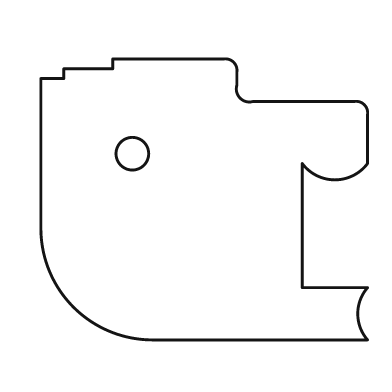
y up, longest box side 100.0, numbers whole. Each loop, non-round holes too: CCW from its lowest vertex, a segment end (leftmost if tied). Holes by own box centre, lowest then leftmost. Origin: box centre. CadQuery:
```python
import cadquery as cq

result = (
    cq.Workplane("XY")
    .moveTo(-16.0, -43.0)
    .lineTo(50.0, -43.0)
    .threePointArc((47.0, -35.0), (50.0, -27.0))
    .lineTo(30.0, -27.0)
    .lineTo(30.0, 11.0)
    .threePointArc((40.0, 6.0), (50.0, 11.0))
    .lineTo(50.0, 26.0)
    .threePointArc((49.0, 29.0), (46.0, 30.0))
    .lineTo(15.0, 30.0)
    .threePointArc((11.0, 31.0), (10.0, 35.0))
    .lineTo(10.0, 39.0)
    .threePointArc((9.0, 42.0), (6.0, 43.0))
    .lineTo(-28.0, 43.0)
    .lineTo(-28.0, 40.0)
    .lineTo(-43.0, 40.0)
    .lineTo(-43.0, 37.0)
    .lineTo(-50.0, 37.0)
    .lineTo(-50.0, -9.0)
    .threePointArc((-40.0, -33.0), (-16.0, -43.0))
    .close()
    .moveTo(-22.0, 14.0)
    .circle(5.0)
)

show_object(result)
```